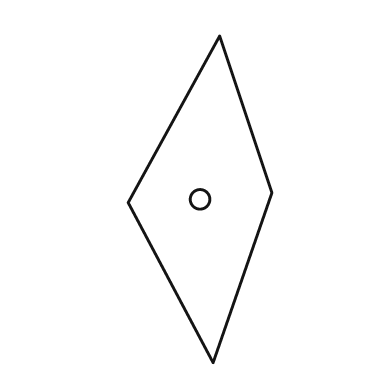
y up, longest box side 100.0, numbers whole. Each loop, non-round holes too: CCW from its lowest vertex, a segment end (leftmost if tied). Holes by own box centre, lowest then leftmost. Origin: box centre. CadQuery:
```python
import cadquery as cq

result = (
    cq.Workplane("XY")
    .moveTo(4.0, -50.0)
    .lineTo(22.0, 2.0)
    .lineTo(6.0, 50.0)
    .lineTo(-22.0, -1.0)
    .close()
    .moveTo(0.0, 0.0)
    .circle(3.0)
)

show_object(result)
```